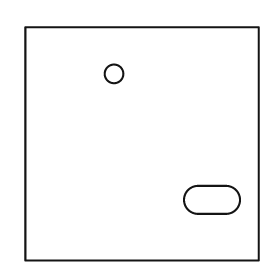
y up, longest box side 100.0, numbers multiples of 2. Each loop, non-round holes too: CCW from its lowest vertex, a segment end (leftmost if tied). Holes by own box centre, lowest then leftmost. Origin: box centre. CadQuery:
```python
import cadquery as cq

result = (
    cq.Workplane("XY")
    .moveTo(-50.0, -50.0)
    .lineTo(50.0, -50.0)
    .lineTo(50.0, 50.0)
    .lineTo(-50.0, 50.0)
    .close()
    .moveTo(24.0, -30.0)
    .lineTo(36.0, -30.0)
    .threePointArc((42.0, -24.0), (36.0, -18.0))
    .lineTo(24.0, -18.0)
    .threePointArc((18.0, -24.0), (24.0, -30.0))
    .close()
    .moveTo(-12.0, 30.0)
    .circle(4.0)
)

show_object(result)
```